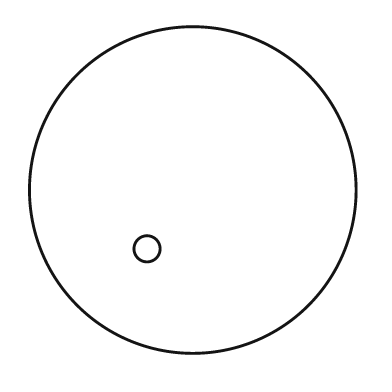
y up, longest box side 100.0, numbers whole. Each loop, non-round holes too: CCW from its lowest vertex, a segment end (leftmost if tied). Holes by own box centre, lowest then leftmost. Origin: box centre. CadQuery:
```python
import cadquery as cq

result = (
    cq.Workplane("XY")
    .moveTo(0.0, 0.0)
    .circle(50.0)
    .moveTo(-14.0, -18.0)
    .circle(4.0)
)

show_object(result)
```